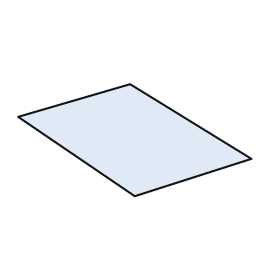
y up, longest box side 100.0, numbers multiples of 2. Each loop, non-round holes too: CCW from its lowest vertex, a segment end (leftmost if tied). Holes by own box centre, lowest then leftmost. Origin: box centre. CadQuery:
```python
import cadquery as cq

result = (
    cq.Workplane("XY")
    .moveTo(0.0, -24.0)
    .lineTo(50.0, -8.0)
    .lineTo(-2.0, 24.0)
    .lineTo(-50.0, 10.0)
    .close()
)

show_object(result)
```